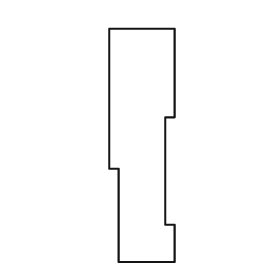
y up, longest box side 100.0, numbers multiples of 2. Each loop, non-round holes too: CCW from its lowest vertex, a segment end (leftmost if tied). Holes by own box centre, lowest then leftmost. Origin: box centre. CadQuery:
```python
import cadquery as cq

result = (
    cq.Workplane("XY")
    .moveTo(-10.0, -50.0)
    .lineTo(14.0, -50.0)
    .lineTo(14.0, -34.0)
    .lineTo(10.0, -34.0)
    .lineTo(10.0, 12.0)
    .lineTo(14.0, 12.0)
    .lineTo(14.0, 50.0)
    .lineTo(-14.0, 50.0)
    .lineTo(-14.0, -10.0)
    .lineTo(-10.0, -10.0)
    .close()
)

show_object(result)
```